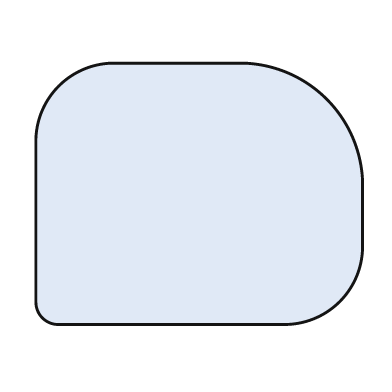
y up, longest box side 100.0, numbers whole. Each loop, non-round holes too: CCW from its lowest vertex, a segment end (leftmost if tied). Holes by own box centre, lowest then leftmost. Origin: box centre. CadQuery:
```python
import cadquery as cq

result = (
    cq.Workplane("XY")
    .moveTo(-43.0, -40.0)
    .lineTo(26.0, -40.0)
    .threePointArc((43.0, -33.0), (50.0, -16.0))
    .lineTo(50.0, 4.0)
    .threePointArc((39.0, 29.0), (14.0, 40.0))
    .lineTo(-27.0, 40.0)
    .threePointArc((-43.0, 33.0), (-50.0, 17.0))
    .lineTo(-50.0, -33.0)
    .threePointArc((-48.0, -38.0), (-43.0, -40.0))
    .close()
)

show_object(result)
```